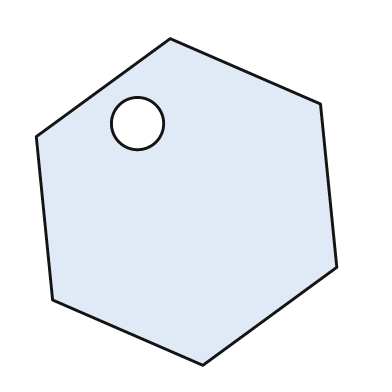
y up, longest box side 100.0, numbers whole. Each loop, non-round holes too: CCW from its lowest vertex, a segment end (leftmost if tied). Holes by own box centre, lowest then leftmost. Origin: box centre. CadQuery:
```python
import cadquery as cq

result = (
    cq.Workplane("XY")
    .moveTo(5.0, -50.0)
    .lineTo(46.0, -20.0)
    .lineTo(41.0, 30.0)
    .lineTo(-5.0, 50.0)
    .lineTo(-46.0, 20.0)
    .lineTo(-41.0, -30.0)
    .close()
    .moveTo(-15.0, 24.0)
    .circle(8.0)
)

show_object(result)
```